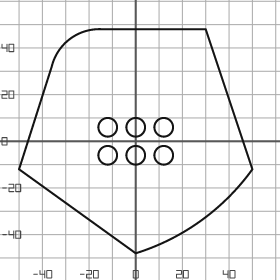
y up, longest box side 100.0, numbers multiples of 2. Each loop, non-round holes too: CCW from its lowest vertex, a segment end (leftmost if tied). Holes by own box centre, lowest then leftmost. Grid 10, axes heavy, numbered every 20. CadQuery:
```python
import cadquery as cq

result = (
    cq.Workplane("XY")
    .moveTo(0.0, -48.0)
    .threePointArc((28.0, -34.0), (50.0, -12.0))
    .lineTo(30.0, 48.0)
    .lineTo(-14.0, 48.0)
    .threePointArc((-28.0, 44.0), (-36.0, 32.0))
    .lineTo(-50.0, -12.0)
    .close()
    .moveTo(-12.0, -6.0)
    .circle(4.0)
    .moveTo(0.0, -6.0)
    .circle(4.0)
    .moveTo(12.0, -6.0)
    .circle(4.0)
    .moveTo(-12.0, 6.0)
    .circle(4.0)
    .moveTo(0.0, 6.0)
    .circle(4.0)
    .moveTo(12.0, 6.0)
    .circle(4.0)
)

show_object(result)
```